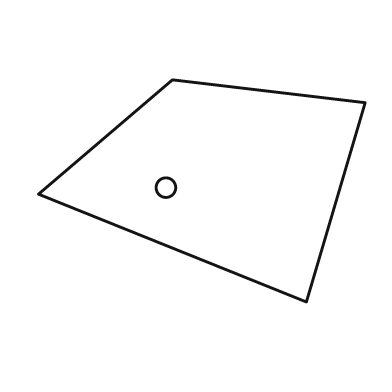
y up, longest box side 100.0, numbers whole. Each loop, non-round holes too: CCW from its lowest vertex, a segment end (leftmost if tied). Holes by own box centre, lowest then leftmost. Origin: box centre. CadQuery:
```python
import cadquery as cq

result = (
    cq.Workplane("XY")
    .moveTo(32.0, -34.0)
    .lineTo(50.0, 27.0)
    .lineTo(-9.0, 34.0)
    .lineTo(-50.0, -1.0)
    .close()
    .moveTo(-11.0, 1.0)
    .circle(3.0)
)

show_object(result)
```